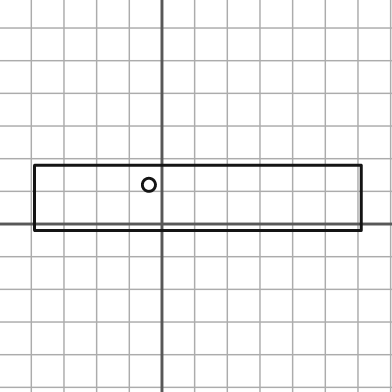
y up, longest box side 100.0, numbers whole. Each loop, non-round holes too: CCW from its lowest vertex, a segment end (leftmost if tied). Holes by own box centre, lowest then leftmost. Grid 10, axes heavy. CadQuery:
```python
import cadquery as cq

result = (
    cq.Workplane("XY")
    .moveTo(-39.0, -2.0)
    .lineTo(61.0, -2.0)
    .lineTo(61.0, 18.0)
    .lineTo(-39.0, 18.0)
    .close()
    .moveTo(-4.0, 12.0)
    .circle(2.0)
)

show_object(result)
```